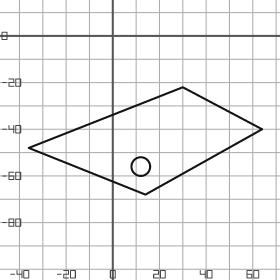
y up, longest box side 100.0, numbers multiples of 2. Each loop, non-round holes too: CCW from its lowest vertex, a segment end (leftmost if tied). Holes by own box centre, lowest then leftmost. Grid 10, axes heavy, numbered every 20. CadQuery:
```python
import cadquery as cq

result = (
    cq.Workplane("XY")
    .moveTo(14.0, -68.0)
    .lineTo(64.0, -40.0)
    .lineTo(30.0, -22.0)
    .lineTo(-36.0, -48.0)
    .close()
    .moveTo(12.0, -56.0)
    .circle(4.0)
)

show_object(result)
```